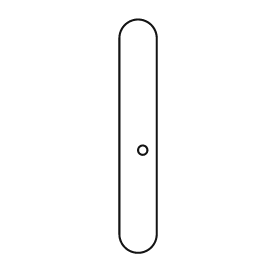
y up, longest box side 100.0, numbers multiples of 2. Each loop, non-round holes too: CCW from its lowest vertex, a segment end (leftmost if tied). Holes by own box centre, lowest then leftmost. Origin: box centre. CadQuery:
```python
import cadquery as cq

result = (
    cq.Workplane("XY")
    .moveTo(-8.0, -42.0)
    .threePointArc((0.0, -50.0), (8.0, -42.0))
    .lineTo(8.0, 42.0)
    .threePointArc((0.0, 50.0), (-8.0, 42.0))
    .close()
    .moveTo(2.0, -6.0)
    .circle(2.0)
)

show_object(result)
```